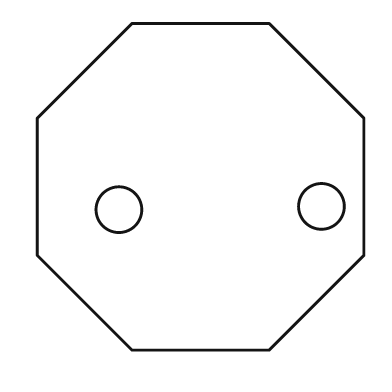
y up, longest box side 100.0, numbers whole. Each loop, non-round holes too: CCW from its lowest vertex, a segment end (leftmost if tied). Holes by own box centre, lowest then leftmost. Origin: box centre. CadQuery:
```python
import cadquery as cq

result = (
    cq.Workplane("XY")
    .moveTo(-21.0, -50.0)
    .lineTo(21.0, -50.0)
    .lineTo(50.0, -21.0)
    .lineTo(50.0, 21.0)
    .lineTo(21.0, 50.0)
    .lineTo(-21.0, 50.0)
    .lineTo(-50.0, 21.0)
    .lineTo(-50.0, -21.0)
    .close()
    .moveTo(-25.0, -7.0)
    .circle(7.0)
    .moveTo(37.0, -6.0)
    .circle(7.0)
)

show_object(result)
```